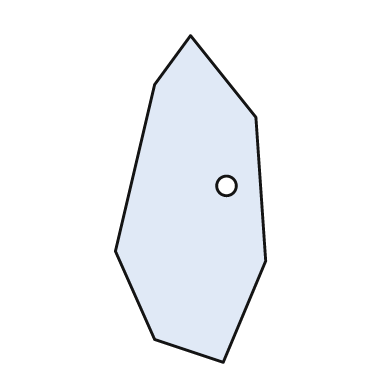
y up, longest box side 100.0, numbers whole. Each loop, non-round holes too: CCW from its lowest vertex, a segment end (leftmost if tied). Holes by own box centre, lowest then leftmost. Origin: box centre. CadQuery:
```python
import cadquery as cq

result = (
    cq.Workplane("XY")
    .moveTo(10.0, -50.0)
    .lineTo(23.0, -19.0)
    .lineTo(20.0, 25.0)
    .lineTo(0.0, 50.0)
    .lineTo(-11.0, 35.0)
    .lineTo(-23.0, -16.0)
    .lineTo(-11.0, -43.0)
    .close()
    .moveTo(11.0, 4.0)
    .circle(3.0)
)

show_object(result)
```